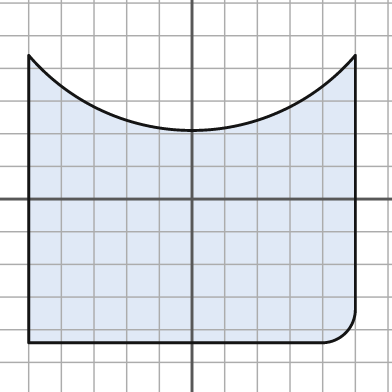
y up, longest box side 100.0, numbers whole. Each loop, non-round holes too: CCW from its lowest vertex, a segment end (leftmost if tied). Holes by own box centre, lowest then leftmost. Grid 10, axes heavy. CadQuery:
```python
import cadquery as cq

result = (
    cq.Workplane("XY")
    .moveTo(-50.0, -44.0)
    .lineTo(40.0, -44.0)
    .threePointArc((47.0, -41.0), (50.0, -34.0))
    .lineTo(50.0, 44.0)
    .threePointArc((0.0, 21.0), (-50.0, 44.0))
    .close()
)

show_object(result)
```